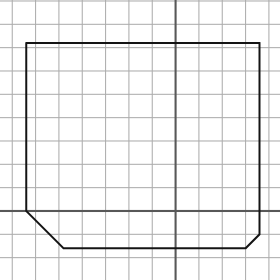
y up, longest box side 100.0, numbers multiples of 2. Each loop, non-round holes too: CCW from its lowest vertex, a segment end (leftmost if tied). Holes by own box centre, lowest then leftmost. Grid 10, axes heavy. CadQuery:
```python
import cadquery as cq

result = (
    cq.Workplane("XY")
    .moveTo(-48.0, -16.0)
    .lineTo(30.0, -16.0)
    .lineTo(36.0, -10.0)
    .lineTo(36.0, 72.0)
    .lineTo(-64.0, 72.0)
    .lineTo(-64.0, 0.0)
    .close()
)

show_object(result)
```